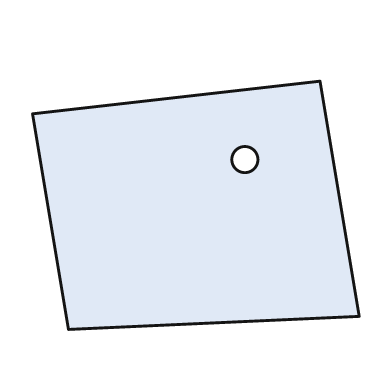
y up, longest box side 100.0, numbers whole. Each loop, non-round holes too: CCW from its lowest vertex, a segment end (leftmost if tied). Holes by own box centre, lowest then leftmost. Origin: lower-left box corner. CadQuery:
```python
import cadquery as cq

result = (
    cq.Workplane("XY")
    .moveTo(11.0, 0.0)
    .lineTo(100.0, 4.0)
    .lineTo(88.0, 76.0)
    .lineTo(0.0, 66.0)
    .close()
    .moveTo(65.0, 52.0)
    .circle(4.0)
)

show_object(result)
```